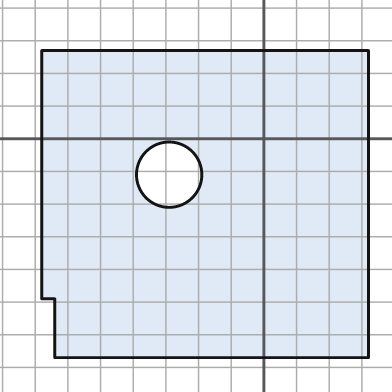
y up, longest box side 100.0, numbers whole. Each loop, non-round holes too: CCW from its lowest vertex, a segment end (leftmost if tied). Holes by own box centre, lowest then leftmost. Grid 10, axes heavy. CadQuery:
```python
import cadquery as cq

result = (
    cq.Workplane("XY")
    .moveTo(-64.0, -67.0)
    .lineTo(32.0, -67.0)
    .lineTo(32.0, 27.0)
    .lineTo(-68.0, 27.0)
    .lineTo(-68.0, -49.0)
    .lineTo(-64.0, -49.0)
    .close()
    .moveTo(-29.0, -11.0)
    .circle(10.0)
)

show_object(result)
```